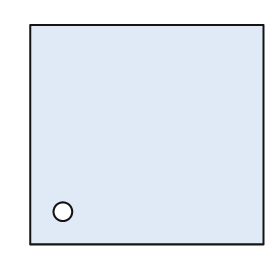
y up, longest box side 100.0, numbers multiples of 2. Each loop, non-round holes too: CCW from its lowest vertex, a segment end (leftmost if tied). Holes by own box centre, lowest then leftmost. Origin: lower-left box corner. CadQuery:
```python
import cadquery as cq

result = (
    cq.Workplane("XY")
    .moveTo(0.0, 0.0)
    .lineTo(100.0, 0.0)
    .lineTo(100.0, 94.0)
    .lineTo(0.0, 94.0)
    .close()
    .moveTo(14.0, 14.0)
    .circle(4.0)
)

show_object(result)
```